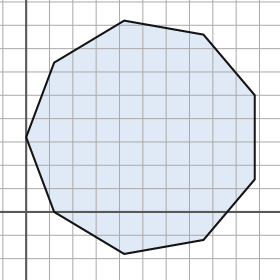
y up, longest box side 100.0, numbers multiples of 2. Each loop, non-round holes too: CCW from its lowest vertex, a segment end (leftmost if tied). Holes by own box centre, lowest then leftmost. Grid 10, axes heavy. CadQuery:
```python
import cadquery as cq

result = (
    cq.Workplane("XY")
    .moveTo(42.0, -18.0)
    .lineTo(76.0, -12.0)
    .lineTo(98.0, 14.0)
    .lineTo(98.0, 50.0)
    .lineTo(76.0, 76.0)
    .lineTo(42.0, 82.0)
    .lineTo(12.0, 64.0)
    .lineTo(0.0, 32.0)
    .lineTo(12.0, 0.0)
    .close()
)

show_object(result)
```